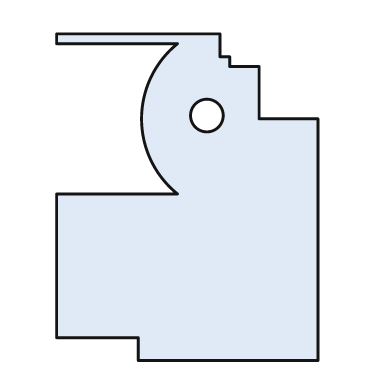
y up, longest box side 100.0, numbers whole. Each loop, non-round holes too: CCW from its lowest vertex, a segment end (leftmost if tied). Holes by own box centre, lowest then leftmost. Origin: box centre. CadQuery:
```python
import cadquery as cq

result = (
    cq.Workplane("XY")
    .moveTo(-15.0, -50.0)
    .lineTo(40.0, -50.0)
    .lineTo(40.0, 24.0)
    .lineTo(22.0, 24.0)
    .lineTo(22.0, 40.0)
    .lineTo(13.0, 40.0)
    .lineTo(13.0, 43.0)
    .lineTo(10.0, 43.0)
    .lineTo(10.0, 50.0)
    .lineTo(-40.0, 50.0)
    .lineTo(-40.0, 47.0)
    .lineTo(-3.0, 47.0)
    .threePointArc((-14.0, 24.0), (-3.0, 1.0))
    .lineTo(-40.0, 1.0)
    .lineTo(-40.0, -43.0)
    .lineTo(-15.0, -43.0)
    .close()
    .moveTo(6.0, 25.0)
    .circle(5.0)
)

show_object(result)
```